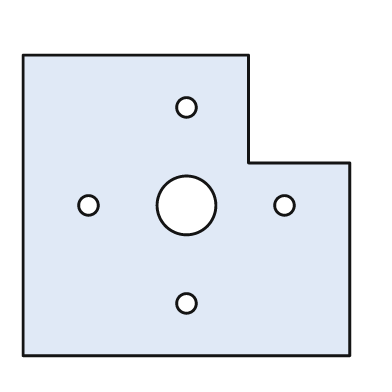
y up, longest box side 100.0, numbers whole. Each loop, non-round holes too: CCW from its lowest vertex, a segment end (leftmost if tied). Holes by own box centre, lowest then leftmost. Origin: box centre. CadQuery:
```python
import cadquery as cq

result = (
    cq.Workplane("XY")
    .moveTo(-50.0, -46.0)
    .lineTo(50.0, -46.0)
    .lineTo(50.0, 13.0)
    .lineTo(19.0, 13.0)
    .lineTo(19.0, 46.0)
    .lineTo(-50.0, 46.0)
    .close()
    .moveTo(0.0, -30.0)
    .circle(3.0)
    .moveTo(-30.0, 0.0)
    .circle(3.0)
    .moveTo(0.0, 0.0)
    .circle(9.0)
    .moveTo(30.0, 0.0)
    .circle(3.0)
    .moveTo(0.0, 30.0)
    .circle(3.0)
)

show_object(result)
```